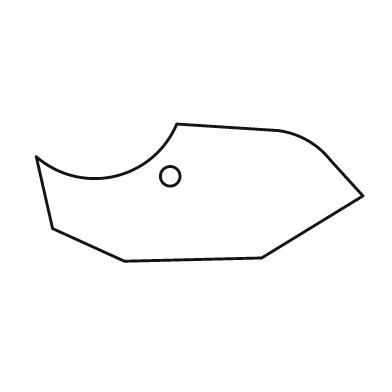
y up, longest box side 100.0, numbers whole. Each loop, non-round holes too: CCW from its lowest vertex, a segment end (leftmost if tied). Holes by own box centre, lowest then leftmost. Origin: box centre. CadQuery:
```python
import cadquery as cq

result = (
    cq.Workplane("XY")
    .moveTo(-23.0, -21.0)
    .lineTo(19.0, -20.0)
    .lineTo(50.0, -1.0)
    .lineTo(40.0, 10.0)
    .threePointArc((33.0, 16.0), (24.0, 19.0))
    .lineTo(-7.0, 21.0)
    .threePointArc((-26.0, 5.0), (-50.0, 11.0))
    .lineTo(-45.0, -11.0)
    .close()
    .moveTo(-9.0, 5.0)
    .circle(3.0)
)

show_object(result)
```